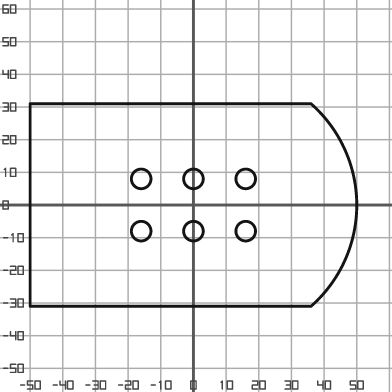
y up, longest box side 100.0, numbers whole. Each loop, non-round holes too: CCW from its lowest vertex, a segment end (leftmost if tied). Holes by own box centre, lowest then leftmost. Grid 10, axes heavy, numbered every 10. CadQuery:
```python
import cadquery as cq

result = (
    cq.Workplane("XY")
    .moveTo(-50.0, -31.0)
    .lineTo(36.0, -31.0)
    .threePointArc((50.0, 0.0), (36.0, 31.0))
    .lineTo(-50.0, 31.0)
    .close()
    .moveTo(-16.0, -8.0)
    .circle(3.0)
    .moveTo(0.0, -8.0)
    .circle(3.0)
    .moveTo(16.0, -8.0)
    .circle(3.0)
    .moveTo(-16.0, 8.0)
    .circle(3.0)
    .moveTo(0.0, 8.0)
    .circle(3.0)
    .moveTo(16.0, 8.0)
    .circle(3.0)
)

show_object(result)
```